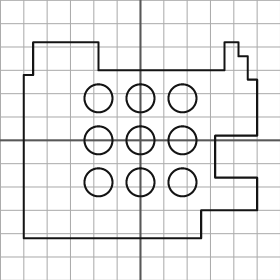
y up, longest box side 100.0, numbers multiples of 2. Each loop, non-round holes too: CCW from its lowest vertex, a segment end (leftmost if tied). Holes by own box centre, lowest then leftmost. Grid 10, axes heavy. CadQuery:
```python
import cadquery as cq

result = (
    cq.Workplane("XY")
    .moveTo(-50.0, -42.0)
    .lineTo(26.0, -42.0)
    .lineTo(26.0, -30.0)
    .lineTo(50.0, -30.0)
    .lineTo(50.0, -16.0)
    .lineTo(32.0, -16.0)
    .lineTo(32.0, 2.0)
    .lineTo(50.0, 2.0)
    .lineTo(50.0, 26.0)
    .lineTo(46.0, 26.0)
    .lineTo(46.0, 36.0)
    .lineTo(42.0, 36.0)
    .lineTo(42.0, 42.0)
    .lineTo(36.0, 42.0)
    .lineTo(36.0, 30.0)
    .lineTo(-18.0, 30.0)
    .lineTo(-18.0, 42.0)
    .lineTo(-46.0, 42.0)
    .lineTo(-46.0, 28.0)
    .lineTo(-50.0, 28.0)
    .close()
    .moveTo(-18.0, -18.0)
    .circle(6.0)
    .moveTo(0.0, -18.0)
    .circle(6.0)
    .moveTo(18.0, -18.0)
    .circle(6.0)
    .moveTo(-18.0, 0.0)
    .circle(6.0)
    .moveTo(0.0, 0.0)
    .circle(6.0)
    .moveTo(18.0, 0.0)
    .circle(6.0)
    .moveTo(-18.0, 18.0)
    .circle(6.0)
    .moveTo(0.0, 18.0)
    .circle(6.0)
    .moveTo(18.0, 18.0)
    .circle(6.0)
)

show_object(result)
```